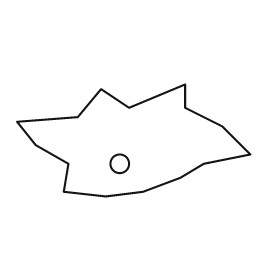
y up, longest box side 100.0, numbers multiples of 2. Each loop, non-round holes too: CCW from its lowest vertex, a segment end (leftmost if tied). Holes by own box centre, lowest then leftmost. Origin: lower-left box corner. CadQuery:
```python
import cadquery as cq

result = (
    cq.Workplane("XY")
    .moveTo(38.0, 0.0)
    .lineTo(54.0, 2.0)
    .lineTo(70.0, 8.0)
    .lineTo(80.0, 14.0)
    .lineTo(100.0, 18.0)
    .lineTo(88.0, 30.0)
    .lineTo(72.0, 38.0)
    .lineTo(72.0, 48.0)
    .lineTo(48.0, 38.0)
    .lineTo(36.0, 46.0)
    .lineTo(26.0, 34.0)
    .lineTo(0.0, 32.0)
    .lineTo(8.0, 22.0)
    .lineTo(22.0, 14.0)
    .lineTo(20.0, 2.0)
    .close()
    .moveTo(44.0, 14.0)
    .circle(4.0)
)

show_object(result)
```